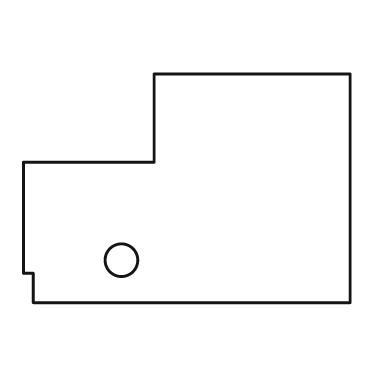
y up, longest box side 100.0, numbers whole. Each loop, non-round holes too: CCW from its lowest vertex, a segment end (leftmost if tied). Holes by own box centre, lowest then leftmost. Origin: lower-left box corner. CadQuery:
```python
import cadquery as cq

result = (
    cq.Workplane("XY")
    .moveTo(3.0, 0.0)
    .lineTo(100.0, 0.0)
    .lineTo(100.0, 70.0)
    .lineTo(40.0, 70.0)
    .lineTo(40.0, 43.0)
    .lineTo(0.0, 43.0)
    .lineTo(0.0, 9.0)
    .lineTo(3.0, 9.0)
    .close()
    .moveTo(30.0, 13.0)
    .circle(5.0)
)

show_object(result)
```